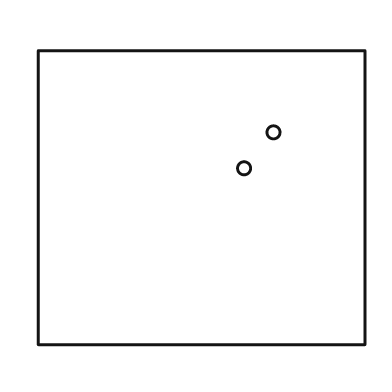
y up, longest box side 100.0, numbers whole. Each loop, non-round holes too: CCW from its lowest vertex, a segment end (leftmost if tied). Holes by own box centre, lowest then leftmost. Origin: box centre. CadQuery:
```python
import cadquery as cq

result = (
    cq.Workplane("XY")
    .moveTo(-50.0, -45.0)
    .lineTo(50.0, -45.0)
    .lineTo(50.0, 45.0)
    .lineTo(-50.0, 45.0)
    .close()
    .moveTo(13.0, 9.0)
    .circle(2.0)
    .moveTo(22.0, 20.0)
    .circle(2.0)
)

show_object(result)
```